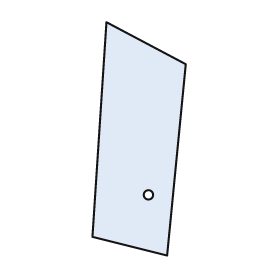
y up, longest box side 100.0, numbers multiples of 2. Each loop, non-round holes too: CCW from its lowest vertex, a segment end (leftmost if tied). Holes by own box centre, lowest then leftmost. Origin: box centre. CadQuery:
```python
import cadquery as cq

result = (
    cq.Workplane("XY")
    .moveTo(12.0, -50.0)
    .lineTo(20.0, 32.0)
    .lineTo(-14.0, 50.0)
    .lineTo(-20.0, -42.0)
    .close()
    .moveTo(4.0, -24.0)
    .circle(2.0)
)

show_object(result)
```